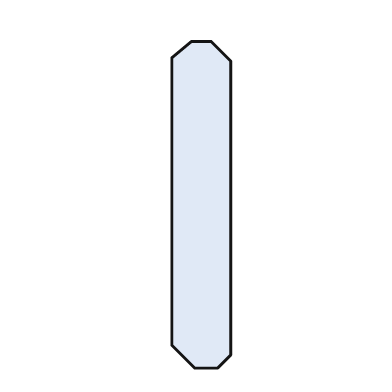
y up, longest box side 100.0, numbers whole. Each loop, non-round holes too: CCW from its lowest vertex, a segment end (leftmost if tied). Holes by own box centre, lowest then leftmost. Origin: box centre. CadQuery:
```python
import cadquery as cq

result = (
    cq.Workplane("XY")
    .moveTo(-2.0, -50.0)
    .lineTo(5.0, -50.0)
    .lineTo(9.0, -46.0)
    .lineTo(9.0, 44.0)
    .lineTo(3.0, 50.0)
    .lineTo(-3.0, 50.0)
    .lineTo(-9.0, 45.0)
    .lineTo(-9.0, -43.0)
    .close()
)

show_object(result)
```